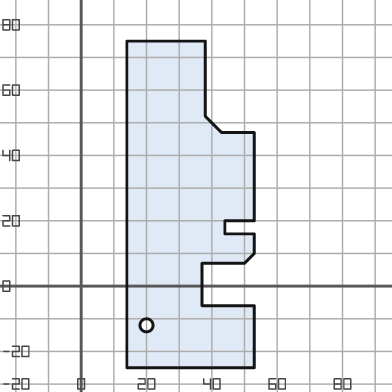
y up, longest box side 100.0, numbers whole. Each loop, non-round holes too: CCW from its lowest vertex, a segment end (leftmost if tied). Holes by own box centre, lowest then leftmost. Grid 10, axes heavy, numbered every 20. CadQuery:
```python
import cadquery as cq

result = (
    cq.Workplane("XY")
    .moveTo(14.0, -25.0)
    .lineTo(53.0, -25.0)
    .lineTo(53.0, -6.0)
    .lineTo(37.0, -6.0)
    .lineTo(37.0, 7.0)
    .lineTo(50.0, 7.0)
    .lineTo(53.0, 10.0)
    .lineTo(53.0, 16.0)
    .lineTo(44.0, 16.0)
    .lineTo(44.0, 20.0)
    .lineTo(53.0, 20.0)
    .lineTo(53.0, 47.0)
    .lineTo(43.0, 47.0)
    .lineTo(38.0, 52.0)
    .lineTo(38.0, 75.0)
    .lineTo(14.0, 75.0)
    .close()
    .moveTo(20.0, -12.0)
    .circle(2.0)
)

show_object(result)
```